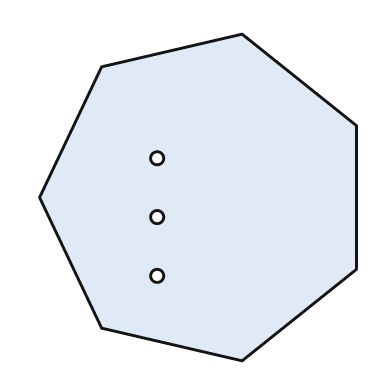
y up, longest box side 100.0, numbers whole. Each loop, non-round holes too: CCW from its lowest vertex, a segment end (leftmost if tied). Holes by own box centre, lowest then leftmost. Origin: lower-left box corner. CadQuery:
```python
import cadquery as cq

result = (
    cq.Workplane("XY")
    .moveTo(62.0, 0.0)
    .lineTo(97.0, 28.0)
    .lineTo(97.0, 72.0)
    .lineTo(62.0, 100.0)
    .lineTo(19.0, 90.0)
    .lineTo(0.0, 50.0)
    .lineTo(19.0, 10.0)
    .close()
    .moveTo(36.0, 26.0)
    .circle(2.0)
    .moveTo(36.0, 44.0)
    .circle(2.0)
    .moveTo(36.0, 62.0)
    .circle(2.0)
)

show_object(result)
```